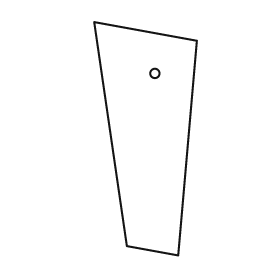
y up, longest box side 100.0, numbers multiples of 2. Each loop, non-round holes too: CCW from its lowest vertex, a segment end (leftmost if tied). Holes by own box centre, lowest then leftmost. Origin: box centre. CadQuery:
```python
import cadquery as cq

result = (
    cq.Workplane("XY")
    .moveTo(14.0, -50.0)
    .lineTo(22.0, 42.0)
    .lineTo(-22.0, 50.0)
    .lineTo(-8.0, -46.0)
    .close()
    .moveTo(4.0, 28.0)
    .circle(2.0)
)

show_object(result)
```